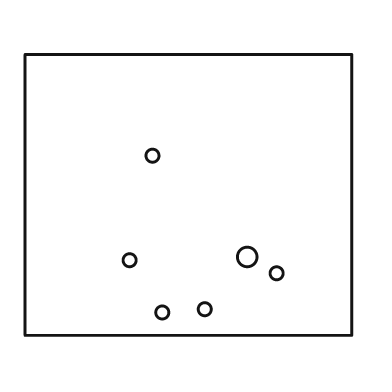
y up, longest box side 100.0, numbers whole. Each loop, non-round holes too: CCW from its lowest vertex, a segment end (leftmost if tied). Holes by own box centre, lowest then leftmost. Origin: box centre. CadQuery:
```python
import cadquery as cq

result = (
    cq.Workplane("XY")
    .moveTo(-50.0, -43.0)
    .lineTo(50.0, -43.0)
    .lineTo(50.0, 43.0)
    .lineTo(-50.0, 43.0)
    .close()
    .moveTo(-8.0, -36.0)
    .circle(2.0)
    .moveTo(5.0, -35.0)
    .circle(2.0)
    .moveTo(27.0, -24.0)
    .circle(2.0)
    .moveTo(-18.0, -20.0)
    .circle(2.0)
    .moveTo(18.0, -19.0)
    .circle(3.0)
    .moveTo(-11.0, 12.0)
    .circle(2.0)
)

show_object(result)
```